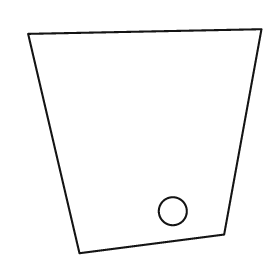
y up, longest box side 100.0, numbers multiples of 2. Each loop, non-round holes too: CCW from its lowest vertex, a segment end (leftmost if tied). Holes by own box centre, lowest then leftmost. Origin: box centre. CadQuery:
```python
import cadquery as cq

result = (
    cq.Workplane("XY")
    .moveTo(-28.0, -48.0)
    .lineTo(34.0, -40.0)
    .lineTo(50.0, 48.0)
    .lineTo(-50.0, 46.0)
    .close()
    .moveTo(12.0, -30.0)
    .circle(6.0)
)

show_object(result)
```